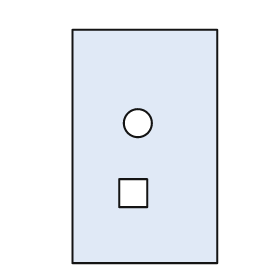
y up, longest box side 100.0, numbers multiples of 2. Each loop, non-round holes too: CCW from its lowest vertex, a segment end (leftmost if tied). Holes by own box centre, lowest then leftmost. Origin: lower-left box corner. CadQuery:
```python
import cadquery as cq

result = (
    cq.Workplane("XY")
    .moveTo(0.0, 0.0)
    .lineTo(62.0, 0.0)
    .lineTo(62.0, 100.0)
    .lineTo(0.0, 100.0)
    .close()
    .moveTo(20.0, 24.0)
    .lineTo(32.0, 24.0)
    .lineTo(32.0, 36.0)
    .lineTo(20.0, 36.0)
    .close()
    .moveTo(28.0, 60.0)
    .circle(6.0)
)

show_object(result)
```